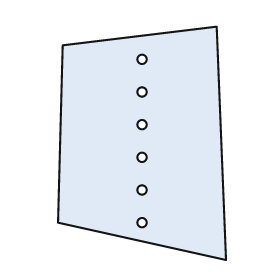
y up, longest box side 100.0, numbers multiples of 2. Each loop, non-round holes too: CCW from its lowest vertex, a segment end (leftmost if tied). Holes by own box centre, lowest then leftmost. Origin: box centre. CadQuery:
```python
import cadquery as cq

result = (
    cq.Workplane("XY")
    .moveTo(36.0, -50.0)
    .lineTo(32.0, 50.0)
    .lineTo(-34.0, 42.0)
    .lineTo(-36.0, -34.0)
    .close()
    .moveTo(0.0, -34.0)
    .circle(2.0)
    .moveTo(0.0, -20.0)
    .circle(2.0)
    .moveTo(0.0, -6.0)
    .circle(2.0)
    .moveTo(0.0, 8.0)
    .circle(2.0)
    .moveTo(0.0, 22.0)
    .circle(2.0)
    .moveTo(0.0, 36.0)
    .circle(2.0)
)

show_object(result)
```